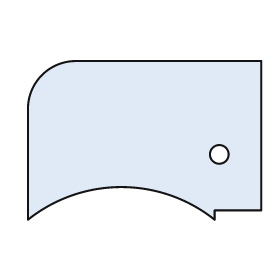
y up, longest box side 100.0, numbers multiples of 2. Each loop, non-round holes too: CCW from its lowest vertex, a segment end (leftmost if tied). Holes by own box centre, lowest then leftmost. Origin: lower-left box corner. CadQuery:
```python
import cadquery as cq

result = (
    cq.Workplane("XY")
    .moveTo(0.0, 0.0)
    .threePointArc((40.0, 14.0), (80.0, 0.0))
    .lineTo(80.0, 4.0)
    .lineTo(100.0, 4.0)
    .lineTo(100.0, 68.0)
    .lineTo(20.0, 68.0)
    .threePointArc((6.0, 62.0), (0.0, 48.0))
    .close()
    .moveTo(82.0, 28.0)
    .circle(4.0)
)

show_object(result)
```